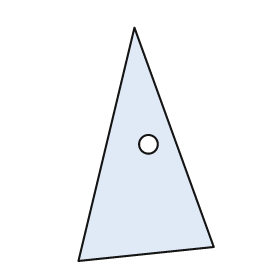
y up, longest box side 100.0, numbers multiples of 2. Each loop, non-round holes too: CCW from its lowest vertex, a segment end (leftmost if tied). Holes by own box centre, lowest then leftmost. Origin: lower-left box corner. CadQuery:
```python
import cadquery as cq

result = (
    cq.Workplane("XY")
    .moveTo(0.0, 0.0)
    .lineTo(58.0, 6.0)
    .lineTo(24.0, 100.0)
    .close()
    .moveTo(30.0, 50.0)
    .circle(4.0)
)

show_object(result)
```